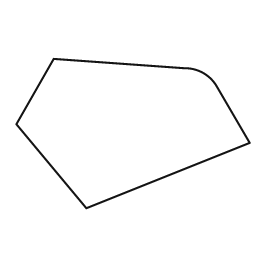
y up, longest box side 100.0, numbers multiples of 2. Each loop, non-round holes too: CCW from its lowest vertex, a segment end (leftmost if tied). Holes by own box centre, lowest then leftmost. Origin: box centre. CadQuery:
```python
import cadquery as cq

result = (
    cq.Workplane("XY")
    .moveTo(-20.0, -32.0)
    .lineTo(50.0, -4.0)
    .lineTo(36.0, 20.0)
    .threePointArc((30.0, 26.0), (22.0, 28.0))
    .lineTo(-34.0, 32.0)
    .lineTo(-50.0, 4.0)
    .close()
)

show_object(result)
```